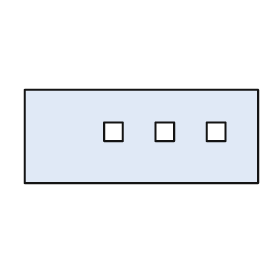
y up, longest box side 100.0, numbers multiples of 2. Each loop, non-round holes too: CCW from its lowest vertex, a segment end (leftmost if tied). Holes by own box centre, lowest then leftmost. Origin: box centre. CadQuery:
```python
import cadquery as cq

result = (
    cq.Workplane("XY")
    .moveTo(-50.0, -20.0)
    .lineTo(50.0, -20.0)
    .lineTo(50.0, 20.0)
    .lineTo(-50.0, 20.0)
    .close()
    .moveTo(-16.0, -2.0)
    .lineTo(-8.0, -2.0)
    .lineTo(-8.0, 6.0)
    .lineTo(-16.0, 6.0)
    .close()
    .moveTo(6.0, -2.0)
    .lineTo(14.0, -2.0)
    .lineTo(14.0, 6.0)
    .lineTo(6.0, 6.0)
    .close()
    .moveTo(28.0, -2.0)
    .lineTo(36.0, -2.0)
    .lineTo(36.0, 6.0)
    .lineTo(28.0, 6.0)
    .close()
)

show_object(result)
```